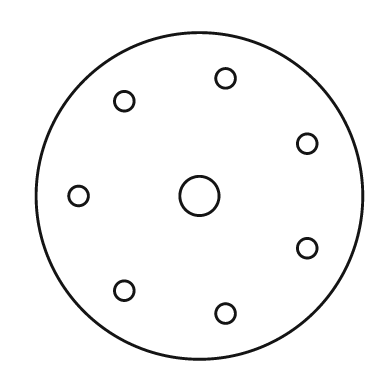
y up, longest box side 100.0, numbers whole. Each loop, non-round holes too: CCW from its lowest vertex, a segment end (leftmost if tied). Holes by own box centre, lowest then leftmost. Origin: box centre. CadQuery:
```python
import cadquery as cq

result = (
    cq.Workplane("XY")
    .moveTo(0.0, 0.0)
    .circle(50.0)
    .moveTo(8.0, -36.0)
    .circle(3.0)
    .moveTo(-23.0, -29.0)
    .circle(3.0)
    .moveTo(33.0, -16.0)
    .circle(3.0)
    .moveTo(-37.0, 0.0)
    .circle(3.0)
    .moveTo(0.0, 0.0)
    .circle(6.0)
    .moveTo(33.0, 16.0)
    .circle(3.0)
    .moveTo(-23.0, 29.0)
    .circle(3.0)
    .moveTo(8.0, 36.0)
    .circle(3.0)
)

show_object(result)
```